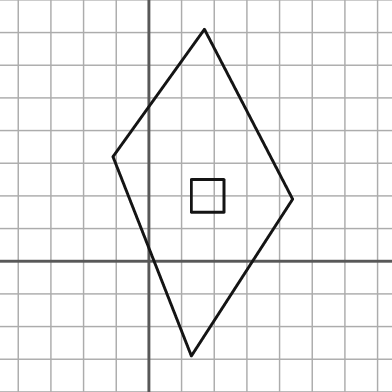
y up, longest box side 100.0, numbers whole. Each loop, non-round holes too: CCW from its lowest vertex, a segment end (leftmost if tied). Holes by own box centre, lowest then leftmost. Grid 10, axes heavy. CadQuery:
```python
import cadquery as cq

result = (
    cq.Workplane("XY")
    .moveTo(13.0, -29.0)
    .lineTo(44.0, 19.0)
    .lineTo(17.0, 71.0)
    .lineTo(-11.0, 32.0)
    .close()
    .moveTo(13.0, 15.0)
    .lineTo(23.0, 15.0)
    .lineTo(23.0, 25.0)
    .lineTo(13.0, 25.0)
    .close()
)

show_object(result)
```